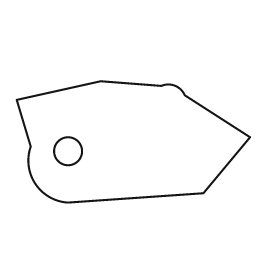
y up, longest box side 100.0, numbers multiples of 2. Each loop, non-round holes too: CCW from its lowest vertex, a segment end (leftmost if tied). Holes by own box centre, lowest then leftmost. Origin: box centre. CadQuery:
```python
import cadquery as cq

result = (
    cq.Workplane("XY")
    .moveTo(-28.0, -26.0)
    .lineTo(30.0, -22.0)
    .lineTo(50.0, 2.0)
    .lineTo(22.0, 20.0)
    .threePointArc((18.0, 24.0), (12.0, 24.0))
    .lineTo(-14.0, 26.0)
    .lineTo(-50.0, 18.0)
    .lineTo(-44.0, -2.0)
    .threePointArc((-42.0, -18.0), (-28.0, -26.0))
    .close()
    .moveTo(-28.0, -4.0)
    .circle(6.0)
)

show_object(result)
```